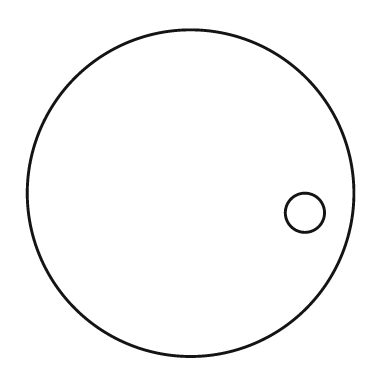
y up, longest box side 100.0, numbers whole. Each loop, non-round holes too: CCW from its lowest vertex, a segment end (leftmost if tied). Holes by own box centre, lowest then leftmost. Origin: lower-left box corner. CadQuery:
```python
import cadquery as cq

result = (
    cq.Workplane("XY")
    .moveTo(50.0, 50.0)
    .circle(50.0)
    .moveTo(85.0, 44.0)
    .circle(6.0)
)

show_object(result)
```